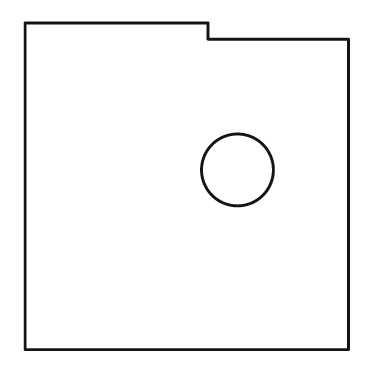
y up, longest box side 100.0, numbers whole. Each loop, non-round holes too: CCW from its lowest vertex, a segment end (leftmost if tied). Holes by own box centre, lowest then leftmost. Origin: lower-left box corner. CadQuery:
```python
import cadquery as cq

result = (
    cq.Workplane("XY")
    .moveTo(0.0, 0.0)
    .lineTo(99.0, 0.0)
    .lineTo(99.0, 95.0)
    .lineTo(56.0, 95.0)
    .lineTo(56.0, 100.0)
    .lineTo(0.0, 100.0)
    .close()
    .moveTo(65.0, 55.0)
    .circle(11.0)
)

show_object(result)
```